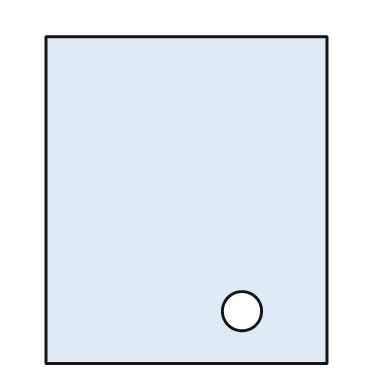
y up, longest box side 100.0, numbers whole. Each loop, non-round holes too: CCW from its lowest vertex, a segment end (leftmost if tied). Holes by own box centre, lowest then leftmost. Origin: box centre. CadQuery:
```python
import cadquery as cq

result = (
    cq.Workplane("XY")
    .moveTo(-43.0, -50.0)
    .lineTo(43.0, -50.0)
    .lineTo(43.0, 50.0)
    .lineTo(-43.0, 50.0)
    .close()
    .moveTo(17.0, -34.0)
    .circle(6.0)
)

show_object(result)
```